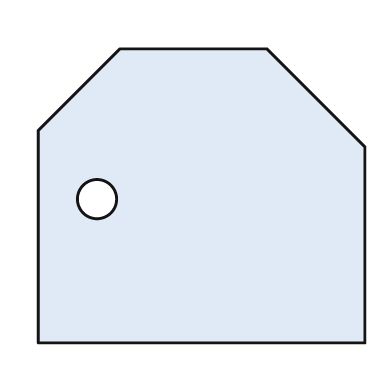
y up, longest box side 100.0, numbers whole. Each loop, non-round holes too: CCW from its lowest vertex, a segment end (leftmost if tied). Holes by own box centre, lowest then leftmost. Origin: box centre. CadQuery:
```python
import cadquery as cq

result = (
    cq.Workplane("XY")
    .moveTo(-50.0, -45.0)
    .lineTo(50.0, -45.0)
    .lineTo(50.0, 15.0)
    .lineTo(20.0, 45.0)
    .lineTo(-25.0, 45.0)
    .lineTo(-50.0, 20.0)
    .close()
    .moveTo(-32.0, -1.0)
    .circle(6.0)
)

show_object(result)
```